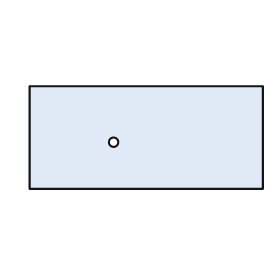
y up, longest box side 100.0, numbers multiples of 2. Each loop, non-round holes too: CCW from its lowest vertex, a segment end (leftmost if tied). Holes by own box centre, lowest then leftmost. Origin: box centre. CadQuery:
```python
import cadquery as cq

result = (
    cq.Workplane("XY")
    .moveTo(-50.0, -22.0)
    .lineTo(50.0, -22.0)
    .lineTo(50.0, 22.0)
    .lineTo(-50.0, 22.0)
    .close()
    .moveTo(-14.0, -2.0)
    .circle(2.0)
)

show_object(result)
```